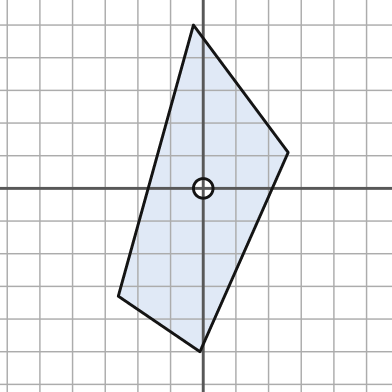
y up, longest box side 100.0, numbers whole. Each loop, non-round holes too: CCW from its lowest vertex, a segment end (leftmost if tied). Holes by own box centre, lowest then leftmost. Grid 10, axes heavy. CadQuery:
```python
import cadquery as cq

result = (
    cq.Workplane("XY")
    .moveTo(-1.0, -50.0)
    .lineTo(26.0, 11.0)
    .lineTo(-3.0, 50.0)
    .lineTo(-26.0, -33.0)
    .close()
    .moveTo(0.0, 0.0)
    .circle(3.0)
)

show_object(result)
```